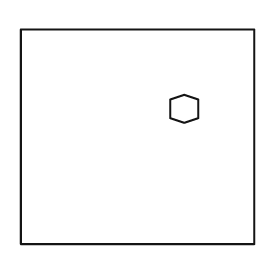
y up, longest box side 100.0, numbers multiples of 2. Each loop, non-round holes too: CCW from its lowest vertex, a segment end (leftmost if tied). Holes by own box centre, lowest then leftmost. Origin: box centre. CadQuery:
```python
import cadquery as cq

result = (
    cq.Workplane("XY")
    .moveTo(-50.0, -46.0)
    .lineTo(50.0, -46.0)
    .lineTo(50.0, 46.0)
    .lineTo(-50.0, 46.0)
    .close()
    .moveTo(20.0, 6.0)
    .lineTo(26.0, 8.0)
    .lineTo(26.0, 16.0)
    .lineTo(20.0, 18.0)
    .lineTo(14.0, 16.0)
    .lineTo(14.0, 8.0)
    .close()
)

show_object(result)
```